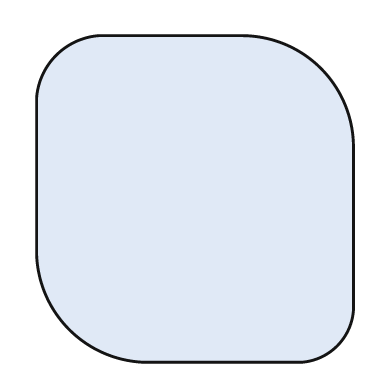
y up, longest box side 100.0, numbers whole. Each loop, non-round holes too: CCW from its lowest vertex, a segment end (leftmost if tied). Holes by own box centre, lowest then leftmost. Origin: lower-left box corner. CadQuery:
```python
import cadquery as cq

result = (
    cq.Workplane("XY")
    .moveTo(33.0, 0.0)
    .lineTo(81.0, 0.0)
    .threePointArc((92.0, 5.0), (97.0, 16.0))
    .lineTo(97.0, 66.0)
    .threePointArc((87.0, 90.0), (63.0, 100.0))
    .lineTo(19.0, 100.0)
    .threePointArc((6.0, 94.0), (0.0, 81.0))
    .lineTo(0.0, 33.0)
    .threePointArc((10.0, 10.0), (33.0, 0.0))
    .close()
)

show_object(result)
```